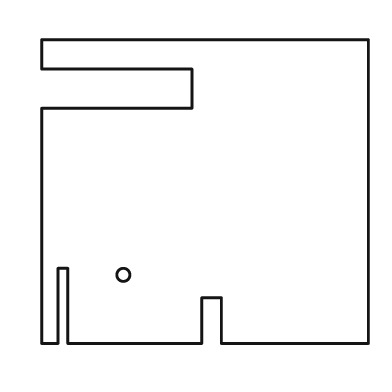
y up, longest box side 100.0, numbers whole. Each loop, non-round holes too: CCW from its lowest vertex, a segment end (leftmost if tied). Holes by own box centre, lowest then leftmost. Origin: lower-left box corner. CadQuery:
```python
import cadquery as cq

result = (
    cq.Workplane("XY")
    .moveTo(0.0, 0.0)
    .lineTo(5.0, 0.0)
    .lineTo(5.0, 23.0)
    .lineTo(8.0, 23.0)
    .lineTo(8.0, 0.0)
    .lineTo(49.0, 0.0)
    .lineTo(49.0, 14.0)
    .lineTo(55.0, 14.0)
    .lineTo(55.0, 0.0)
    .lineTo(100.0, 0.0)
    .lineTo(100.0, 93.0)
    .lineTo(0.0, 93.0)
    .lineTo(0.0, 84.0)
    .lineTo(46.0, 84.0)
    .lineTo(46.0, 72.0)
    .lineTo(0.0, 72.0)
    .close()
    .moveTo(25.0, 21.0)
    .circle(2.0)
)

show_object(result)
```